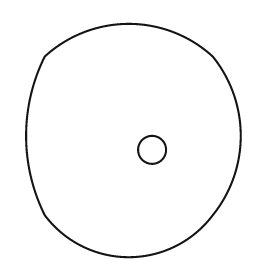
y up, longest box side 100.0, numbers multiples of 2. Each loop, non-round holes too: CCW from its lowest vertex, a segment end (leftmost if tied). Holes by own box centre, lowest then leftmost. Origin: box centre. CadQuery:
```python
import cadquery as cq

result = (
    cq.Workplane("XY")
    .moveTo(-38.0, -32.0)
    .threePointArc((-2.0, -50.0), (34.0, -32.0))
    .threePointArc((46.0, 2.0), (34.0, 36.0))
    .threePointArc((-2.0, 50.0), (-38.0, 36.0))
    .threePointArc((-46.0, 2.0), (-38.0, -32.0))
    .close()
    .moveTo(8.0, -4.0)
    .circle(6.0)
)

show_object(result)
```